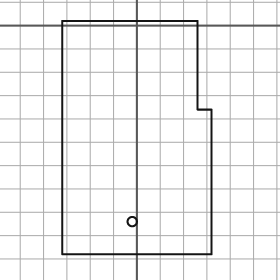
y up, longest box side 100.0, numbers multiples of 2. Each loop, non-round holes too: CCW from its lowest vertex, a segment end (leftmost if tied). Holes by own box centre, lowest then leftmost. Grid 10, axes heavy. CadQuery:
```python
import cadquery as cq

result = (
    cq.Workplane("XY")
    .moveTo(-32.0, -98.0)
    .lineTo(32.0, -98.0)
    .lineTo(32.0, -36.0)
    .lineTo(26.0, -36.0)
    .lineTo(26.0, 2.0)
    .lineTo(-32.0, 2.0)
    .close()
    .moveTo(-2.0, -84.0)
    .circle(2.0)
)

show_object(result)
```